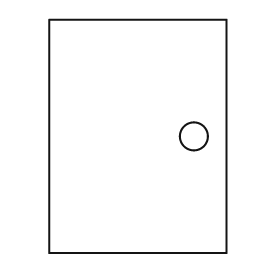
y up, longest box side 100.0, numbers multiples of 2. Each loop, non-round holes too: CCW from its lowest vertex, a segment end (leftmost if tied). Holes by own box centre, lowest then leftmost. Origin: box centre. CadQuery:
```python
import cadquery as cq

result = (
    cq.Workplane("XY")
    .moveTo(-38.0, -50.0)
    .lineTo(38.0, -50.0)
    .lineTo(38.0, 50.0)
    .lineTo(-38.0, 50.0)
    .close()
    .moveTo(24.0, 0.0)
    .circle(6.0)
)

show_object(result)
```